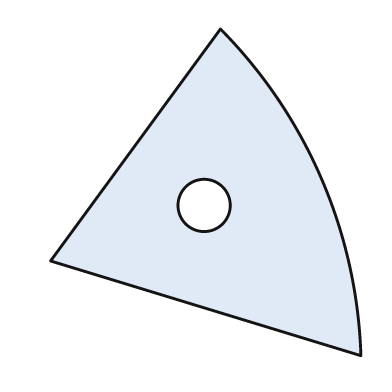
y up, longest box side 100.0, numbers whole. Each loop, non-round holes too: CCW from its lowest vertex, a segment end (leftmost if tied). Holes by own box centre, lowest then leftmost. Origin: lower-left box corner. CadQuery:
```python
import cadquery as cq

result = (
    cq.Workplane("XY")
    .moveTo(95.0, 0.0)
    .threePointArc((83.0, 54.0), (52.0, 100.0))
    .lineTo(0.0, 29.0)
    .close()
    .moveTo(47.0, 46.0)
    .circle(8.0)
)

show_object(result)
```